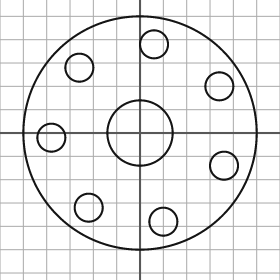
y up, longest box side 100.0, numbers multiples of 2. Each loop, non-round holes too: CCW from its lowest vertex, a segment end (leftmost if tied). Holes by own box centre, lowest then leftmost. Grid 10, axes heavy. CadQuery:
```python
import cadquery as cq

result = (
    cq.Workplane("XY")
    .moveTo(0.0, 0.0)
    .circle(50.0)
    .moveTo(10.0, -38.0)
    .circle(6.0)
    .moveTo(-22.0, -32.0)
    .circle(6.0)
    .moveTo(36.0, -14.0)
    .circle(6.0)
    .moveTo(-38.0, -2.0)
    .circle(6.0)
    .moveTo(0.0, 0.0)
    .circle(14.0)
    .moveTo(34.0, 20.0)
    .circle(6.0)
    .moveTo(-26.0, 28.0)
    .circle(6.0)
    .moveTo(6.0, 38.0)
    .circle(6.0)
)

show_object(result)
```